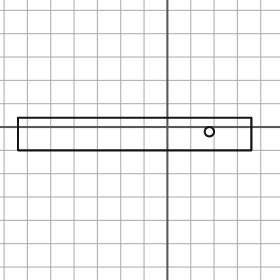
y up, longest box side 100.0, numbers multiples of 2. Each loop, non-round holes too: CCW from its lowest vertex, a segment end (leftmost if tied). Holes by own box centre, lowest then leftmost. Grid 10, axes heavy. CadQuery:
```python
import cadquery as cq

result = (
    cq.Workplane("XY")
    .moveTo(-64.0, -10.0)
    .lineTo(36.0, -10.0)
    .lineTo(36.0, 4.0)
    .lineTo(-64.0, 4.0)
    .close()
    .moveTo(18.0, -2.0)
    .circle(2.0)
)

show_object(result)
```